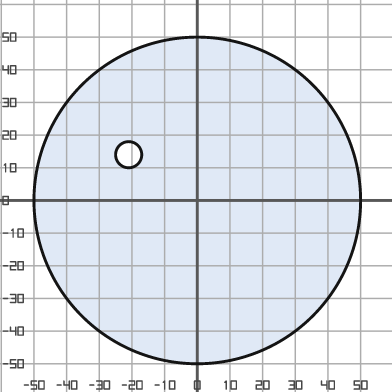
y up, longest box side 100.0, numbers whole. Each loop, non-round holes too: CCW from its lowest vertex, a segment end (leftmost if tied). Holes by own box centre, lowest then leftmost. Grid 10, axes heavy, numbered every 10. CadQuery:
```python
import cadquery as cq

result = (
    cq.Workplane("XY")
    .moveTo(0.0, 0.0)
    .circle(50.0)
    .moveTo(-21.0, 14.0)
    .circle(4.0)
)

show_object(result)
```